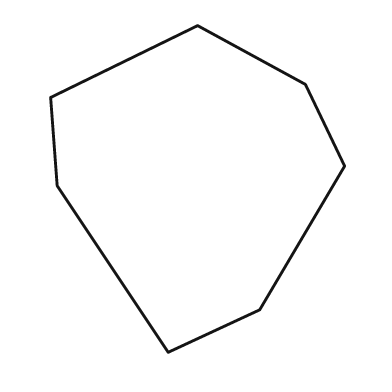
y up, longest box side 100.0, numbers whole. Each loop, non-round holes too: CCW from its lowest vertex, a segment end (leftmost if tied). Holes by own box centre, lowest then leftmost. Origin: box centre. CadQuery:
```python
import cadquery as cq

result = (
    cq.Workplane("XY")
    .moveTo(-9.0, -50.0)
    .lineTo(19.0, -37.0)
    .lineTo(45.0, 7.0)
    .lineTo(33.0, 32.0)
    .lineTo(0.0, 50.0)
    .lineTo(-45.0, 28.0)
    .lineTo(-43.0, 1.0)
    .close()
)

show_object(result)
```